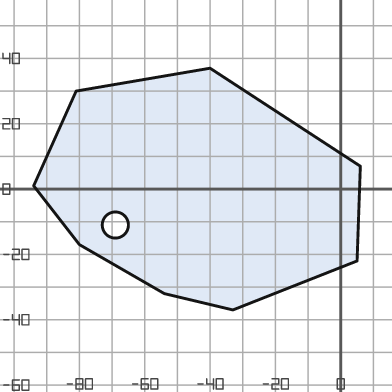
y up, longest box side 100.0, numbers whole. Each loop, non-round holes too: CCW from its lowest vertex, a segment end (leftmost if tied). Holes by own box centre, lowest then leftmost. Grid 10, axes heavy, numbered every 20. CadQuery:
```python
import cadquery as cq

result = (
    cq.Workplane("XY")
    .moveTo(-33.0, -37.0)
    .lineTo(5.0, -22.0)
    .lineTo(6.0, 7.0)
    .lineTo(-40.0, 37.0)
    .lineTo(-81.0, 30.0)
    .lineTo(-94.0, 1.0)
    .lineTo(-80.0, -17.0)
    .lineTo(-54.0, -32.0)
    .close()
    .moveTo(-69.0, -11.0)
    .circle(4.0)
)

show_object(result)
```